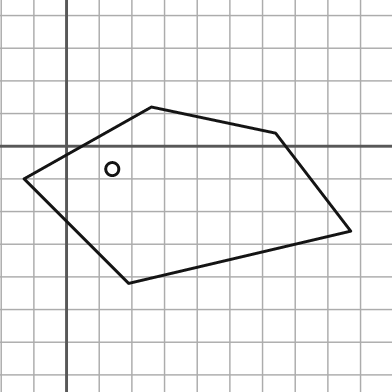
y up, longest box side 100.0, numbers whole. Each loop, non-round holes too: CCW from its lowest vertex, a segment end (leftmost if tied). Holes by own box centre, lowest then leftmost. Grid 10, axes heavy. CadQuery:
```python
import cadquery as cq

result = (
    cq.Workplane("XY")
    .moveTo(19.0, -42.0)
    .lineTo(87.0, -26.0)
    .lineTo(64.0, 4.0)
    .lineTo(26.0, 12.0)
    .lineTo(-13.0, -10.0)
    .close()
    .moveTo(14.0, -7.0)
    .circle(2.0)
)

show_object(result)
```